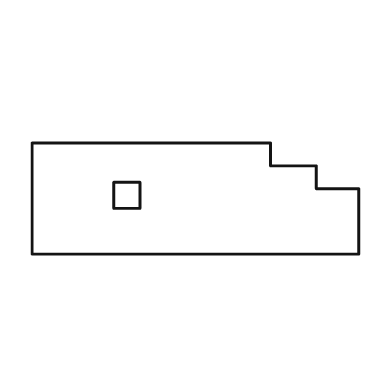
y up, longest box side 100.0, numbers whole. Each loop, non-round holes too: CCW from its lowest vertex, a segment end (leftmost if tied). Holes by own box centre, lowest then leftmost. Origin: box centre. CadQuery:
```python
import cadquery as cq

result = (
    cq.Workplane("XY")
    .moveTo(-50.0, -17.0)
    .lineTo(50.0, -17.0)
    .lineTo(50.0, 3.0)
    .lineTo(37.0, 3.0)
    .lineTo(37.0, 10.0)
    .lineTo(23.0, 10.0)
    .lineTo(23.0, 17.0)
    .lineTo(-50.0, 17.0)
    .close()
    .moveTo(-25.0, -3.0)
    .lineTo(-17.0, -3.0)
    .lineTo(-17.0, 5.0)
    .lineTo(-25.0, 5.0)
    .close()
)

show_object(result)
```